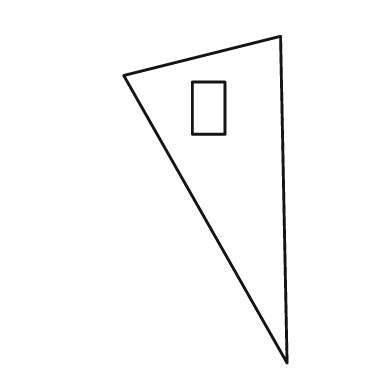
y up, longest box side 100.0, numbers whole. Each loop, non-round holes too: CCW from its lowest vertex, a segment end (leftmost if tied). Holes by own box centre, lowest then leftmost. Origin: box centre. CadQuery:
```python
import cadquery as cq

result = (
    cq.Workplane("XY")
    .moveTo(25.0, -50.0)
    .lineTo(23.0, 50.0)
    .lineTo(-25.0, 38.0)
    .close()
    .moveTo(-4.0, 20.0)
    .lineTo(6.0, 20.0)
    .lineTo(6.0, 36.0)
    .lineTo(-4.0, 36.0)
    .close()
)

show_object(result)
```